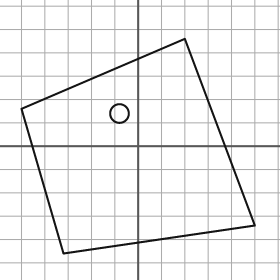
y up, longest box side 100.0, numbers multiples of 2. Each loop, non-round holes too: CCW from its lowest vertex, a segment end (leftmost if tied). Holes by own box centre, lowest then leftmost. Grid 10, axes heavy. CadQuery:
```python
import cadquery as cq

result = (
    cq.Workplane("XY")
    .moveTo(-32.0, -46.0)
    .lineTo(50.0, -34.0)
    .lineTo(20.0, 46.0)
    .lineTo(-50.0, 16.0)
    .close()
    .moveTo(-8.0, 14.0)
    .circle(4.0)
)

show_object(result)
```